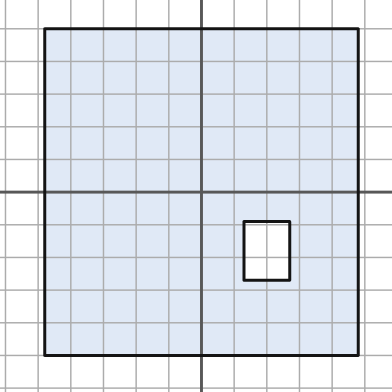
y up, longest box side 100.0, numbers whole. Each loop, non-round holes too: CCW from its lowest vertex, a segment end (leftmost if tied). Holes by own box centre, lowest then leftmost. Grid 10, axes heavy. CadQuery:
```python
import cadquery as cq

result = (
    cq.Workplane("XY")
    .moveTo(-48.0, -50.0)
    .lineTo(48.0, -50.0)
    .lineTo(48.0, 50.0)
    .lineTo(-48.0, 50.0)
    .close()
    .moveTo(13.0, -27.0)
    .lineTo(27.0, -27.0)
    .lineTo(27.0, -9.0)
    .lineTo(13.0, -9.0)
    .close()
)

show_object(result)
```